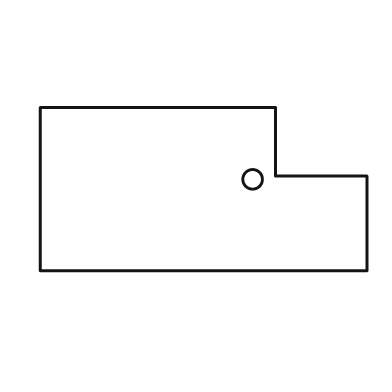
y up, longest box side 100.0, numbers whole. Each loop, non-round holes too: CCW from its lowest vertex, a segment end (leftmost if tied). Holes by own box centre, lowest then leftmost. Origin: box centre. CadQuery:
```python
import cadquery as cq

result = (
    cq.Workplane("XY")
    .moveTo(-50.0, -25.0)
    .lineTo(50.0, -25.0)
    .lineTo(50.0, 4.0)
    .lineTo(22.0, 4.0)
    .lineTo(22.0, 25.0)
    .lineTo(-50.0, 25.0)
    .close()
    .moveTo(15.0, 3.0)
    .circle(3.0)
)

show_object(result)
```